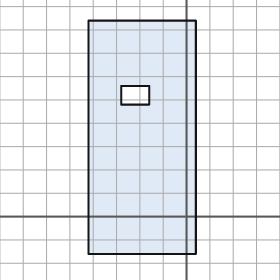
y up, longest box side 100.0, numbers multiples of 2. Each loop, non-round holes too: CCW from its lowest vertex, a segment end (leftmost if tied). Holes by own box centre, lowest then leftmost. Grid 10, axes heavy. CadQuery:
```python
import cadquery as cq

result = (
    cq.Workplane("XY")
    .moveTo(-42.0, -16.0)
    .lineTo(4.0, -16.0)
    .lineTo(4.0, 84.0)
    .lineTo(-42.0, 84.0)
    .close()
    .moveTo(-28.0, 48.0)
    .lineTo(-16.0, 48.0)
    .lineTo(-16.0, 56.0)
    .lineTo(-28.0, 56.0)
    .close()
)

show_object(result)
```